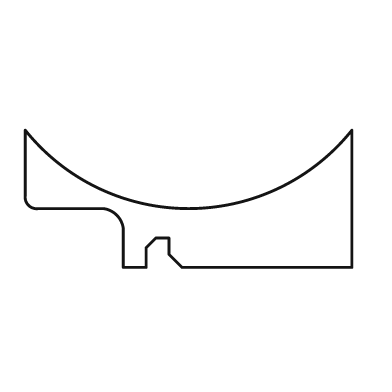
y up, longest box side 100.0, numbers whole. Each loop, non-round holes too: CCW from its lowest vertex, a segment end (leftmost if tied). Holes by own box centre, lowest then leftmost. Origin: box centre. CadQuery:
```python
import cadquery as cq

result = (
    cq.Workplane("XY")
    .moveTo(-20.0, -21.0)
    .lineTo(-13.0, -21.0)
    .lineTo(-13.0, -15.0)
    .lineTo(-10.0, -12.0)
    .lineTo(-6.0, -12.0)
    .lineTo(-6.0, -17.0)
    .lineTo(-2.0, -21.0)
    .lineTo(50.0, -21.0)
    .lineTo(50.0, 21.0)
    .threePointArc((0.0, -3.0), (-50.0, 21.0))
    .lineTo(-50.0, 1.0)
    .threePointArc((-49.0, -2.0), (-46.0, -3.0))
    .lineTo(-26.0, -3.0)
    .threePointArc((-22.0, -5.0), (-20.0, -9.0))
    .close()
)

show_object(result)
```